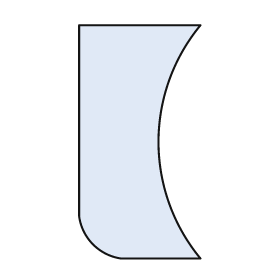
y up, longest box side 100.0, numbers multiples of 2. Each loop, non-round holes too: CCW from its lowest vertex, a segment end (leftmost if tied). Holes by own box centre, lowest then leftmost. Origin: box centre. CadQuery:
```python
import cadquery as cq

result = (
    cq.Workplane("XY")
    .moveTo(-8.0, -50.0)
    .lineTo(26.0, -50.0)
    .threePointArc((8.0, 0.0), (26.0, 50.0))
    .lineTo(-26.0, 50.0)
    .lineTo(-26.0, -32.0)
    .threePointArc((-20.0, -44.0), (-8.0, -50.0))
    .close()
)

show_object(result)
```